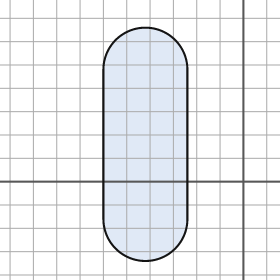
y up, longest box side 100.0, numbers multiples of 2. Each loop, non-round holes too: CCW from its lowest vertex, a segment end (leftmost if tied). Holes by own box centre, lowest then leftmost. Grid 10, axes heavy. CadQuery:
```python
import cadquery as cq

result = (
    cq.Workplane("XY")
    .moveTo(-60.0, -16.0)
    .threePointArc((-42.0, -34.0), (-24.0, -16.0))
    .lineTo(-24.0, 48.0)
    .threePointArc((-42.0, 66.0), (-60.0, 48.0))
    .close()
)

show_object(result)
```